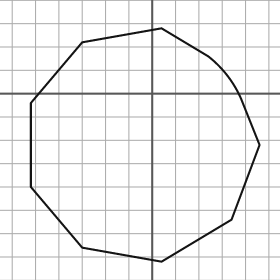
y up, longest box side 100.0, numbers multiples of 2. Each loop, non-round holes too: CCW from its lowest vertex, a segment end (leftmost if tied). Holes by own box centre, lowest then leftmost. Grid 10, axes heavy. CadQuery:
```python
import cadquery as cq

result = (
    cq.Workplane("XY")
    .moveTo(4.0, -72.0)
    .lineTo(34.0, -54.0)
    .lineTo(46.0, -22.0)
    .lineTo(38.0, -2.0)
    .threePointArc((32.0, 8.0), (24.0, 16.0))
    .lineTo(4.0, 28.0)
    .lineTo(-30.0, 22.0)
    .lineTo(-52.0, -4.0)
    .lineTo(-52.0, -40.0)
    .lineTo(-30.0, -66.0)
    .close()
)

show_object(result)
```